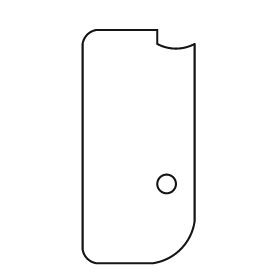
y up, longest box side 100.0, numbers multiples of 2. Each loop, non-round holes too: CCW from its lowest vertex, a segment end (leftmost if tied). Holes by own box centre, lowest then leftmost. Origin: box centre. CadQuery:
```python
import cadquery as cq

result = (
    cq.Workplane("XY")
    .moveTo(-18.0, -50.0)
    .lineTo(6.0, -50.0)
    .threePointArc((18.0, -44.0), (24.0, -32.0))
    .lineTo(24.0, 44.0)
    .threePointArc((16.0, 42.0), (8.0, 44.0))
    .lineTo(8.0, 50.0)
    .lineTo(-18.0, 50.0)
    .threePointArc((-22.0, 48.0), (-24.0, 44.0))
    .lineTo(-24.0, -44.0)
    .threePointArc((-22.0, -48.0), (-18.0, -50.0))
    .close()
    .moveTo(12.0, -16.0)
    .circle(4.0)
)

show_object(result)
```